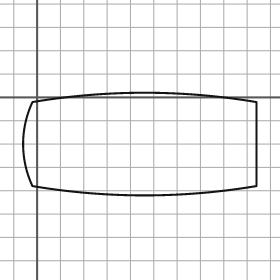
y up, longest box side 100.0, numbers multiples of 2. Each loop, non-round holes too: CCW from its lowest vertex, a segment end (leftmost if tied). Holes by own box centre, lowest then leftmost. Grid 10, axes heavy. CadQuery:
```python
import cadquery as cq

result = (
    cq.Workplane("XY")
    .moveTo(-2.0, -38.0)
    .threePointArc((46.0, -42.0), (94.0, -38.0))
    .lineTo(94.0, -2.0)
    .threePointArc((46.0, 2.0), (-2.0, -2.0))
    .threePointArc((-6.0, -20.0), (-2.0, -38.0))
    .close()
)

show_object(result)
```